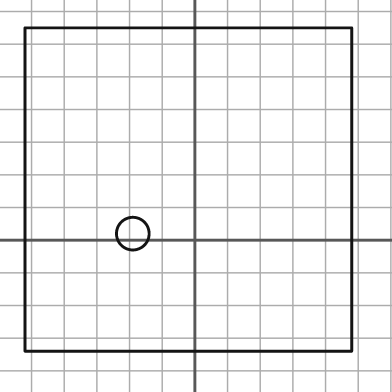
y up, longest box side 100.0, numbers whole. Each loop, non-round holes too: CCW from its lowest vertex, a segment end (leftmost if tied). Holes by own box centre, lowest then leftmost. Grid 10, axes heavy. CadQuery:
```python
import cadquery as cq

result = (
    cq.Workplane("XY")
    .moveTo(-52.0, -34.0)
    .lineTo(48.0, -34.0)
    .lineTo(48.0, 65.0)
    .lineTo(-52.0, 65.0)
    .close()
    .moveTo(-19.0, 2.0)
    .circle(5.0)
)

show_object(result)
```